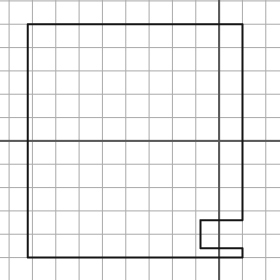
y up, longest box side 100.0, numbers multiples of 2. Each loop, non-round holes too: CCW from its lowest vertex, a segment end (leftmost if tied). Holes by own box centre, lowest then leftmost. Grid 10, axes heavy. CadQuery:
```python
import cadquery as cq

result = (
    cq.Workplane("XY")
    .moveTo(-82.0, -50.0)
    .lineTo(10.0, -50.0)
    .lineTo(10.0, -46.0)
    .lineTo(-8.0, -46.0)
    .lineTo(-8.0, -34.0)
    .lineTo(10.0, -34.0)
    .lineTo(10.0, 50.0)
    .lineTo(-82.0, 50.0)
    .close()
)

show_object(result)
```